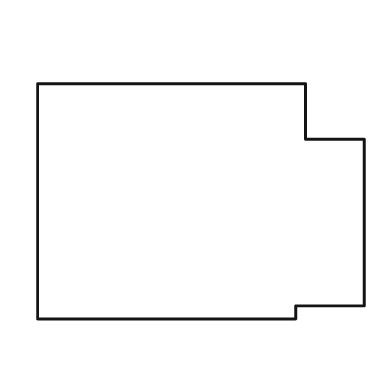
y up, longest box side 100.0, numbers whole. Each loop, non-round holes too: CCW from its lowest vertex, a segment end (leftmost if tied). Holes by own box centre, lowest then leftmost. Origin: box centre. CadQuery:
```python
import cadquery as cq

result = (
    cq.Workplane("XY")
    .moveTo(-50.0, -36.0)
    .lineTo(29.0, -36.0)
    .lineTo(29.0, -32.0)
    .lineTo(50.0, -32.0)
    .lineTo(50.0, 19.0)
    .lineTo(32.0, 19.0)
    .lineTo(32.0, 36.0)
    .lineTo(-50.0, 36.0)
    .close()
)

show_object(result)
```